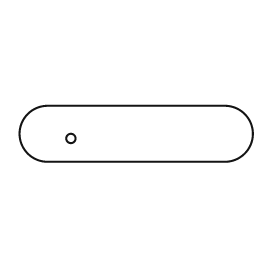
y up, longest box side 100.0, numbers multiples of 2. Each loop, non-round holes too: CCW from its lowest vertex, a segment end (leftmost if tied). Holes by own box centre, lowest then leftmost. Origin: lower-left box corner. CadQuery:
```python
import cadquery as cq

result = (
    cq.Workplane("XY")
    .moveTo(12.0, 0.0)
    .lineTo(88.0, 0.0)
    .threePointArc((100.0, 12.0), (88.0, 24.0))
    .lineTo(12.0, 24.0)
    .threePointArc((0.0, 12.0), (12.0, 0.0))
    .close()
    .moveTo(22.0, 10.0)
    .circle(2.0)
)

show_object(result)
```